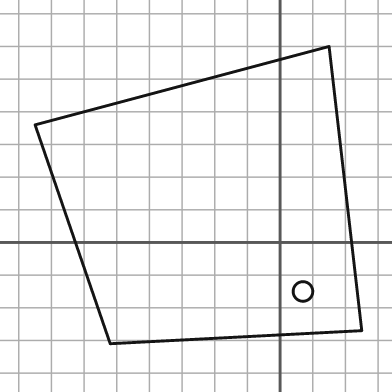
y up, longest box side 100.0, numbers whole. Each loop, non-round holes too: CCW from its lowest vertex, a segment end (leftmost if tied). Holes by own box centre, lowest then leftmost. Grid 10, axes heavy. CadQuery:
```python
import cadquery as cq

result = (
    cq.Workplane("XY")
    .moveTo(-52.0, -31.0)
    .lineTo(25.0, -27.0)
    .lineTo(15.0, 60.0)
    .lineTo(-75.0, 36.0)
    .close()
    .moveTo(7.0, -15.0)
    .circle(3.0)
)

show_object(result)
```